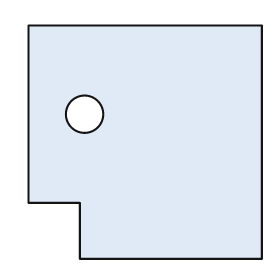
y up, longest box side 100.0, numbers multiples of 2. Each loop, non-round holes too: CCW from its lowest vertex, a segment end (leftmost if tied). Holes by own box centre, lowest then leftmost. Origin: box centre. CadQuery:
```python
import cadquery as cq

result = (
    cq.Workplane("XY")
    .moveTo(-28.0, -50.0)
    .lineTo(50.0, -50.0)
    .lineTo(50.0, 50.0)
    .lineTo(-50.0, 50.0)
    .lineTo(-50.0, -26.0)
    .lineTo(-28.0, -26.0)
    .close()
    .moveTo(-26.0, 12.0)
    .circle(8.0)
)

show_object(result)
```